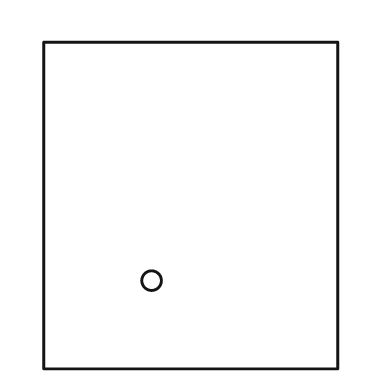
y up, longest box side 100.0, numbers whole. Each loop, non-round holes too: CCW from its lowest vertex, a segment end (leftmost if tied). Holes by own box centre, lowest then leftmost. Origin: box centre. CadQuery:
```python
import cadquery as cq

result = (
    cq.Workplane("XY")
    .moveTo(-45.0, -50.0)
    .lineTo(45.0, -50.0)
    .lineTo(45.0, 50.0)
    .lineTo(-45.0, 50.0)
    .close()
    .moveTo(-12.0, -23.0)
    .circle(3.0)
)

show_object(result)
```